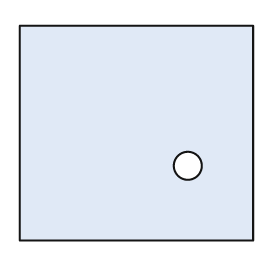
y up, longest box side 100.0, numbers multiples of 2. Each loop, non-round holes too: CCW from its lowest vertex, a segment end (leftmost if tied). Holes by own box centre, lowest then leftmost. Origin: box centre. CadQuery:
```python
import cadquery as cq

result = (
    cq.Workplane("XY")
    .moveTo(-50.0, -46.0)
    .lineTo(50.0, -46.0)
    .lineTo(50.0, 46.0)
    .lineTo(-50.0, 46.0)
    .close()
    .moveTo(22.0, -14.0)
    .circle(6.0)
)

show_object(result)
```